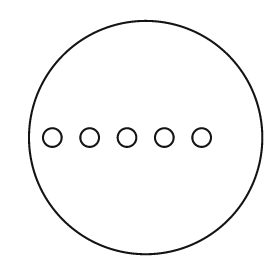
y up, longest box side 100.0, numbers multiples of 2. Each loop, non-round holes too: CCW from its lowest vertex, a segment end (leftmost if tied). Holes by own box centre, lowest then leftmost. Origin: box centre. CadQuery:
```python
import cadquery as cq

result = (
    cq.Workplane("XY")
    .moveTo(0.0, 0.0)
    .circle(50.0)
    .moveTo(-40.0, 0.0)
    .circle(4.0)
    .moveTo(-24.0, 0.0)
    .circle(4.0)
    .moveTo(-8.0, 0.0)
    .circle(4.0)
    .moveTo(8.0, 0.0)
    .circle(4.0)
    .moveTo(24.0, 0.0)
    .circle(4.0)
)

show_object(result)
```